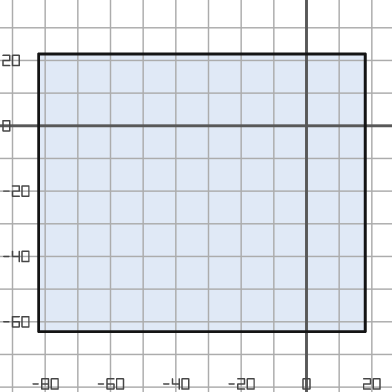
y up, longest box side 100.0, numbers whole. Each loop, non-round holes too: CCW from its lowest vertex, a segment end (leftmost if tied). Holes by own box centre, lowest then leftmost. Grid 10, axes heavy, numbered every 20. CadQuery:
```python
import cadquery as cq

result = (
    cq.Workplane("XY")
    .moveTo(-82.0, -63.0)
    .lineTo(18.0, -63.0)
    .lineTo(18.0, 22.0)
    .lineTo(-82.0, 22.0)
    .close()
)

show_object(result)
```